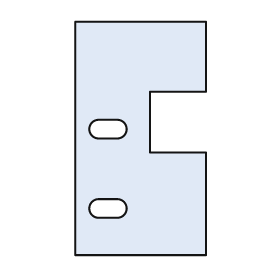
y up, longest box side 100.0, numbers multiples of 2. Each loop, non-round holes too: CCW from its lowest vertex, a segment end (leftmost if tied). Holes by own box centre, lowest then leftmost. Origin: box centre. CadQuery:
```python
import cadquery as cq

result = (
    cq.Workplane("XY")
    .moveTo(-28.0, -50.0)
    .lineTo(28.0, -50.0)
    .lineTo(28.0, -6.0)
    .lineTo(4.0, -6.0)
    .lineTo(4.0, 20.0)
    .lineTo(28.0, 20.0)
    .lineTo(28.0, 50.0)
    .lineTo(-28.0, 50.0)
    .close()
    .moveTo(-18.0, -34.0)
    .lineTo(-10.0, -34.0)
    .threePointArc((-6.0, -30.0), (-10.0, -26.0))
    .lineTo(-18.0, -26.0)
    .threePointArc((-22.0, -30.0), (-18.0, -34.0))
    .close()
    .moveTo(-18.0, 0.0)
    .lineTo(-10.0, 0.0)
    .threePointArc((-6.0, 4.0), (-10.0, 8.0))
    .lineTo(-18.0, 8.0)
    .threePointArc((-22.0, 4.0), (-18.0, 0.0))
    .close()
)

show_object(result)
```